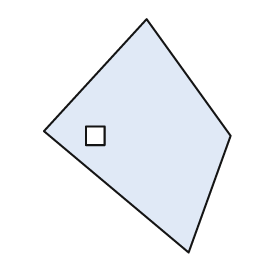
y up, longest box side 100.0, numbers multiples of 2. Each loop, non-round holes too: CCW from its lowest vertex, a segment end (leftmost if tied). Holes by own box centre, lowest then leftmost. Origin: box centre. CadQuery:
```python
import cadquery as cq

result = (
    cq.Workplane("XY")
    .moveTo(22.0, -50.0)
    .lineTo(40.0, 0.0)
    .lineTo(4.0, 50.0)
    .lineTo(-40.0, 2.0)
    .close()
    .moveTo(-22.0, -4.0)
    .lineTo(-14.0, -4.0)
    .lineTo(-14.0, 4.0)
    .lineTo(-22.0, 4.0)
    .close()
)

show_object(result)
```